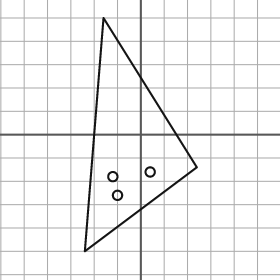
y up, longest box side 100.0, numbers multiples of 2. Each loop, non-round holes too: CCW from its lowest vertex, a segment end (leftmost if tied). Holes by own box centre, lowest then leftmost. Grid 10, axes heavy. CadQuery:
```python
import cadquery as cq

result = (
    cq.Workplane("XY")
    .moveTo(-24.0, -50.0)
    .lineTo(24.0, -14.0)
    .lineTo(-16.0, 50.0)
    .close()
    .moveTo(-10.0, -26.0)
    .circle(2.0)
    .moveTo(-12.0, -18.0)
    .circle(2.0)
    .moveTo(4.0, -16.0)
    .circle(2.0)
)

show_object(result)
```